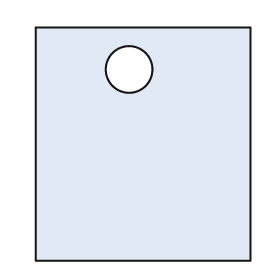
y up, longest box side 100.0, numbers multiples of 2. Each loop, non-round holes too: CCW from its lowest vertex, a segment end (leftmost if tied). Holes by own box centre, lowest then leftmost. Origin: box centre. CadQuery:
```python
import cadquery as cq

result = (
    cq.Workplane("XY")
    .moveTo(-46.0, -50.0)
    .lineTo(46.0, -50.0)
    .lineTo(46.0, 50.0)
    .lineTo(-46.0, 50.0)
    .close()
    .moveTo(-6.0, 32.0)
    .circle(10.0)
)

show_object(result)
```